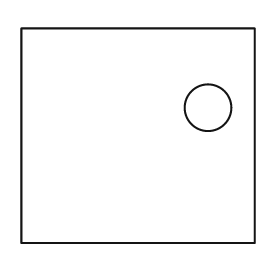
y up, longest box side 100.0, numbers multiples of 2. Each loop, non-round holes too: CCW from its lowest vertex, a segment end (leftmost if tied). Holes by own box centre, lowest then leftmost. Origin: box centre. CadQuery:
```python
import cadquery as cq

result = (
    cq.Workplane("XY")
    .moveTo(-50.0, -46.0)
    .lineTo(50.0, -46.0)
    .lineTo(50.0, 46.0)
    .lineTo(-50.0, 46.0)
    .close()
    .moveTo(30.0, 12.0)
    .circle(10.0)
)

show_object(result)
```